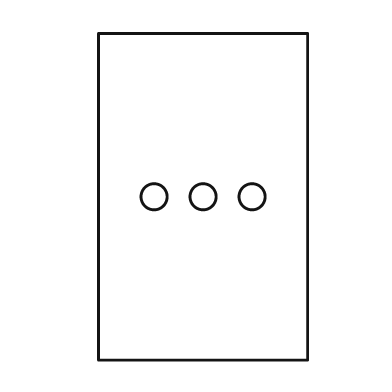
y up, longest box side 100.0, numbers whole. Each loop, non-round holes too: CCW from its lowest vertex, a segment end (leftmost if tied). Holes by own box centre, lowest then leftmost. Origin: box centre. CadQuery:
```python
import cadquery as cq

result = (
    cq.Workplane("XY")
    .moveTo(-32.0, -50.0)
    .lineTo(32.0, -50.0)
    .lineTo(32.0, 50.0)
    .lineTo(-32.0, 50.0)
    .close()
    .moveTo(-15.0, 0.0)
    .circle(4.0)
    .moveTo(0.0, 0.0)
    .circle(4.0)
    .moveTo(15.0, 0.0)
    .circle(4.0)
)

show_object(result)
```